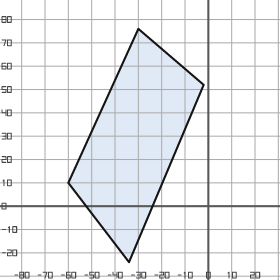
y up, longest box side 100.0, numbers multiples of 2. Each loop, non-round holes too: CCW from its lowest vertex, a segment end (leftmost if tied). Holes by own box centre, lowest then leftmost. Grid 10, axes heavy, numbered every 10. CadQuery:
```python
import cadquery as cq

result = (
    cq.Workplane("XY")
    .moveTo(-34.0, -24.0)
    .lineTo(-2.0, 52.0)
    .lineTo(-30.0, 76.0)
    .lineTo(-60.0, 10.0)
    .close()
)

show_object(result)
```